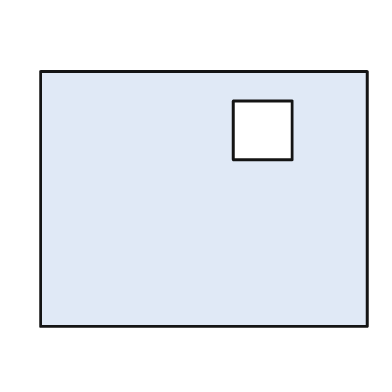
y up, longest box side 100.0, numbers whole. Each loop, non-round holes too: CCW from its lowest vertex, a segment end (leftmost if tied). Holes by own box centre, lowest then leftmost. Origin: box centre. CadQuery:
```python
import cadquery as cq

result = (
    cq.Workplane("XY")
    .moveTo(-50.0, -39.0)
    .lineTo(50.0, -39.0)
    .lineTo(50.0, 39.0)
    .lineTo(-50.0, 39.0)
    .close()
    .moveTo(9.0, 12.0)
    .lineTo(27.0, 12.0)
    .lineTo(27.0, 30.0)
    .lineTo(9.0, 30.0)
    .close()
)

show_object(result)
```